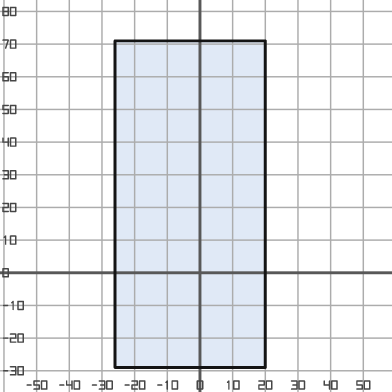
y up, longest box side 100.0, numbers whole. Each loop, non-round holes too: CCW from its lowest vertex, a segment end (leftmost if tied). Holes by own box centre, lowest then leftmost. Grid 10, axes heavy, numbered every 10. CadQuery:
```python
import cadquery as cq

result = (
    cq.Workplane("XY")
    .moveTo(-26.0, -29.0)
    .lineTo(20.0, -29.0)
    .lineTo(20.0, 71.0)
    .lineTo(-26.0, 71.0)
    .close()
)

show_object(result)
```